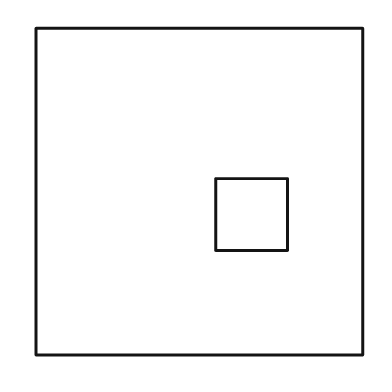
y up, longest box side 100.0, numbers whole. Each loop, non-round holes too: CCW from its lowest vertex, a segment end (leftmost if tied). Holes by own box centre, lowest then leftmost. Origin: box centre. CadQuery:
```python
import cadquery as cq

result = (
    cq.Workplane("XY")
    .moveTo(-50.0, -50.0)
    .lineTo(50.0, -50.0)
    .lineTo(50.0, 50.0)
    .lineTo(-50.0, 50.0)
    .close()
    .moveTo(5.0, -18.0)
    .lineTo(27.0, -18.0)
    .lineTo(27.0, 4.0)
    .lineTo(5.0, 4.0)
    .close()
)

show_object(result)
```